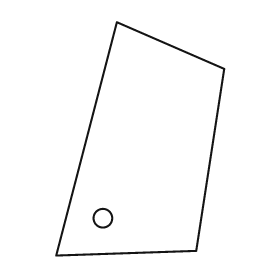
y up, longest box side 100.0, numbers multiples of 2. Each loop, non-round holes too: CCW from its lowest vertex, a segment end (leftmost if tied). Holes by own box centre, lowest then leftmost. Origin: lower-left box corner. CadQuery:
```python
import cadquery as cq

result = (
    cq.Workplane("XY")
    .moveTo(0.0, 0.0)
    .lineTo(60.0, 2.0)
    .lineTo(72.0, 80.0)
    .lineTo(26.0, 100.0)
    .close()
    .moveTo(20.0, 16.0)
    .circle(4.0)
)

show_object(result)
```